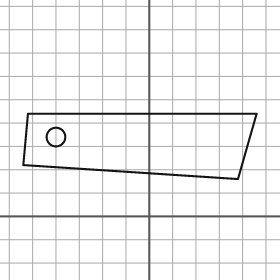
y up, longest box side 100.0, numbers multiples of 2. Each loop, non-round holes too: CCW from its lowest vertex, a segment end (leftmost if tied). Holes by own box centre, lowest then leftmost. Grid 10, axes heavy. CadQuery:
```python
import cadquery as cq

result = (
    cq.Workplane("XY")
    .moveTo(38.0, 16.0)
    .lineTo(46.0, 44.0)
    .lineTo(-52.0, 44.0)
    .lineTo(-54.0, 22.0)
    .close()
    .moveTo(-40.0, 34.0)
    .circle(4.0)
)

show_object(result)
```